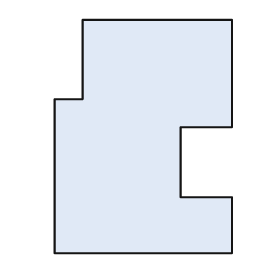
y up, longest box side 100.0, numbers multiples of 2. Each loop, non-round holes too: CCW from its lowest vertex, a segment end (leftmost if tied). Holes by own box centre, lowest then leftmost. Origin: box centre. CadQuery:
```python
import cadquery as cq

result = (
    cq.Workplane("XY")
    .moveTo(-38.0, -50.0)
    .lineTo(38.0, -50.0)
    .lineTo(38.0, -26.0)
    .lineTo(16.0, -26.0)
    .lineTo(16.0, 4.0)
    .lineTo(38.0, 4.0)
    .lineTo(38.0, 50.0)
    .lineTo(-26.0, 50.0)
    .lineTo(-26.0, 16.0)
    .lineTo(-38.0, 16.0)
    .close()
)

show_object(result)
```